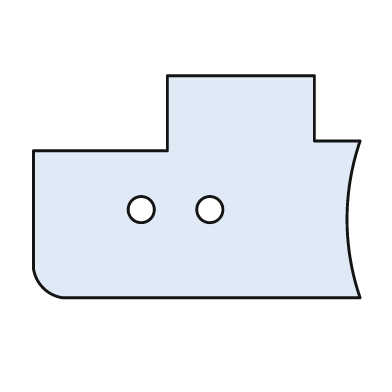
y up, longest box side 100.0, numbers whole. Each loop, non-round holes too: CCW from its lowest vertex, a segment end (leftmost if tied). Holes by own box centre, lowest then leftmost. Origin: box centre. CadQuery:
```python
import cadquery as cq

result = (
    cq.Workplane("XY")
    .moveTo(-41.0, -34.0)
    .lineTo(50.0, -34.0)
    .threePointArc((46.0, -10.0), (50.0, 14.0))
    .lineTo(36.0, 14.0)
    .lineTo(36.0, 34.0)
    .lineTo(-9.0, 34.0)
    .lineTo(-9.0, 11.0)
    .lineTo(-50.0, 11.0)
    .lineTo(-50.0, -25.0)
    .threePointArc((-47.0, -31.0), (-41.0, -34.0))
    .close()
    .moveTo(-17.0, -7.0)
    .circle(4.0)
    .moveTo(4.0, -7.0)
    .circle(4.0)
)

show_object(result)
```